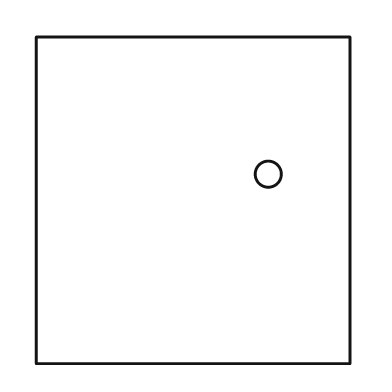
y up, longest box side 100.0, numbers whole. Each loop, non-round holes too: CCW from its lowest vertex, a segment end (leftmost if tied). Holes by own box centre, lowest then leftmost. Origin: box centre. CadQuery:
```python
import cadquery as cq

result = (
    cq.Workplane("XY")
    .moveTo(-48.0, -50.0)
    .lineTo(48.0, -50.0)
    .lineTo(48.0, 50.0)
    .lineTo(-48.0, 50.0)
    .close()
    .moveTo(23.0, 8.0)
    .circle(4.0)
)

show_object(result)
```